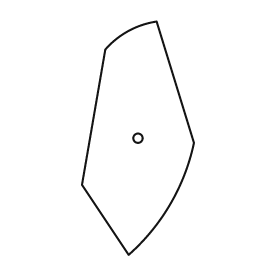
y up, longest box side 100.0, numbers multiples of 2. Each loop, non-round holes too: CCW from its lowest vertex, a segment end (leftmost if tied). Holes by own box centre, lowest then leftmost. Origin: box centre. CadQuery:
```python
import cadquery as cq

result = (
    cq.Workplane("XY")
    .moveTo(-4.0, -50.0)
    .threePointArc((14.0, -28.0), (24.0, -2.0))
    .lineTo(8.0, 50.0)
    .threePointArc((-4.0, 46.0), (-14.0, 38.0))
    .lineTo(-24.0, -20.0)
    .close()
    .moveTo(0.0, 0.0)
    .circle(2.0)
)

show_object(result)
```